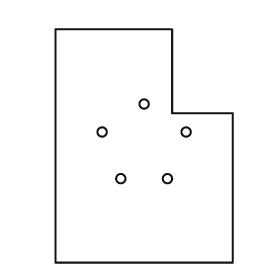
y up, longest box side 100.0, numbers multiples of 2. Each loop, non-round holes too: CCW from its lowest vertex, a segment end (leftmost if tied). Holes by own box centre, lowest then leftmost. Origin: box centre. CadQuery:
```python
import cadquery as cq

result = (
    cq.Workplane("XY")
    .moveTo(-38.0, -50.0)
    .lineTo(38.0, -50.0)
    .lineTo(38.0, 14.0)
    .lineTo(12.0, 14.0)
    .lineTo(12.0, 50.0)
    .lineTo(-38.0, 50.0)
    .close()
    .moveTo(-10.0, -14.0)
    .circle(2.0)
    .moveTo(10.0, -14.0)
    .circle(2.0)
    .moveTo(-18.0, 6.0)
    .circle(2.0)
    .moveTo(18.0, 6.0)
    .circle(2.0)
    .moveTo(0.0, 18.0)
    .circle(2.0)
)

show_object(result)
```